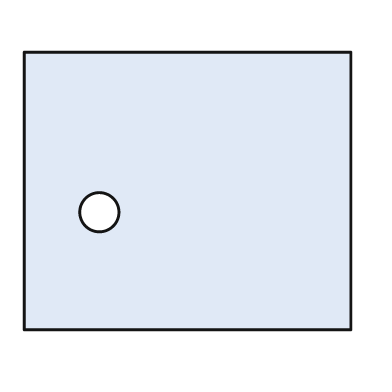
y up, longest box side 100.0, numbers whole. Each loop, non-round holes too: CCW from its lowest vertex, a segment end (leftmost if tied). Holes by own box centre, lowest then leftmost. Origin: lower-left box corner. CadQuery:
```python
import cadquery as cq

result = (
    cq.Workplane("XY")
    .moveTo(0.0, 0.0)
    .lineTo(100.0, 0.0)
    .lineTo(100.0, 85.0)
    .lineTo(0.0, 85.0)
    .close()
    .moveTo(23.0, 36.0)
    .circle(6.0)
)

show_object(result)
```